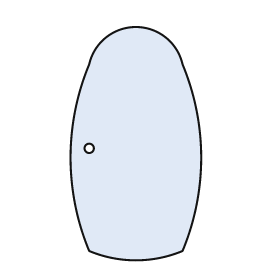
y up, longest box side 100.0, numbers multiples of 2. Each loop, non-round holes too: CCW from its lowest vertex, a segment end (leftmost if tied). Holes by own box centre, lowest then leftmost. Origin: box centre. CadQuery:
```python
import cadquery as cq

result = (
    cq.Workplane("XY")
    .moveTo(-20.0, -46.0)
    .threePointArc((0.0, -50.0), (20.0, -46.0))
    .threePointArc((28.0, -6.0), (20.0, 34.0))
    .threePointArc((0.0, 50.0), (-20.0, 34.0))
    .threePointArc((-28.0, -6.0), (-20.0, -46.0))
    .close()
    .moveTo(-20.0, -2.0)
    .circle(2.0)
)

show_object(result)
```